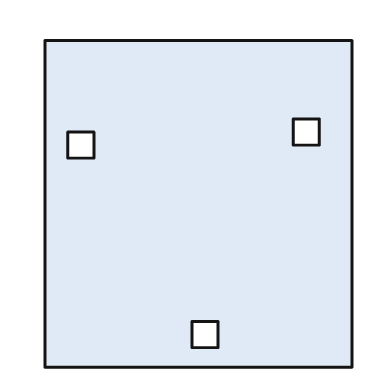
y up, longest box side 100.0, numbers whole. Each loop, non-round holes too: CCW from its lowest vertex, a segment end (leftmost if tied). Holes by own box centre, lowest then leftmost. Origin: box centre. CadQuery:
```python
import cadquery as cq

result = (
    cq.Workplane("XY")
    .moveTo(-47.0, -50.0)
    .lineTo(47.0, -50.0)
    .lineTo(47.0, 50.0)
    .lineTo(-47.0, 50.0)
    .close()
    .moveTo(-2.0, -44.0)
    .lineTo(6.0, -44.0)
    .lineTo(6.0, -36.0)
    .lineTo(-2.0, -36.0)
    .close()
    .moveTo(-40.0, 14.0)
    .lineTo(-32.0, 14.0)
    .lineTo(-32.0, 22.0)
    .lineTo(-40.0, 22.0)
    .close()
    .moveTo(29.0, 18.0)
    .lineTo(37.0, 18.0)
    .lineTo(37.0, 26.0)
    .lineTo(29.0, 26.0)
    .close()
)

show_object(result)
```